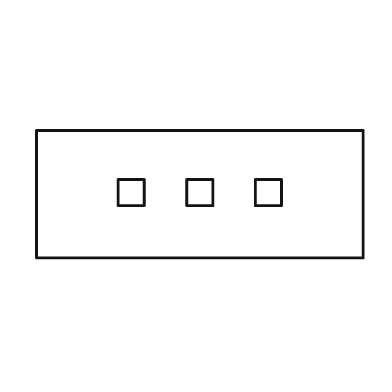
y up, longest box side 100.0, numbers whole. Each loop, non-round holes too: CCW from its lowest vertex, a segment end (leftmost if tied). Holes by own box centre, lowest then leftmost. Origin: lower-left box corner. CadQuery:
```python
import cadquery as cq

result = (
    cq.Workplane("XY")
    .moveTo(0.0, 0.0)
    .lineTo(100.0, 0.0)
    .lineTo(100.0, 39.0)
    .lineTo(0.0, 39.0)
    .close()
    .moveTo(25.0, 16.0)
    .lineTo(33.0, 16.0)
    .lineTo(33.0, 24.0)
    .lineTo(25.0, 24.0)
    .close()
    .moveTo(46.0, 16.0)
    .lineTo(54.0, 16.0)
    .lineTo(54.0, 24.0)
    .lineTo(46.0, 24.0)
    .close()
    .moveTo(67.0, 16.0)
    .lineTo(75.0, 16.0)
    .lineTo(75.0, 24.0)
    .lineTo(67.0, 24.0)
    .close()
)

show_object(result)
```